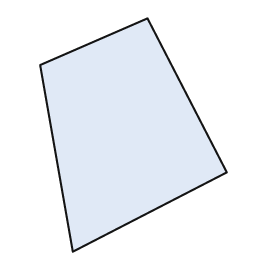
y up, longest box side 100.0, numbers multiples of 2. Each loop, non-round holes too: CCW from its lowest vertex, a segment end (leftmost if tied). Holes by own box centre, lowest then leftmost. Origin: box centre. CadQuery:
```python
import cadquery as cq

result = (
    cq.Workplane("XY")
    .moveTo(-26.0, -50.0)
    .lineTo(40.0, -16.0)
    .lineTo(6.0, 50.0)
    .lineTo(-40.0, 30.0)
    .close()
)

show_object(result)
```